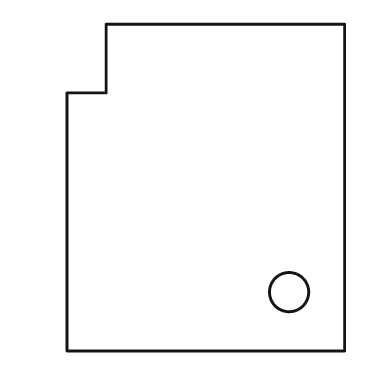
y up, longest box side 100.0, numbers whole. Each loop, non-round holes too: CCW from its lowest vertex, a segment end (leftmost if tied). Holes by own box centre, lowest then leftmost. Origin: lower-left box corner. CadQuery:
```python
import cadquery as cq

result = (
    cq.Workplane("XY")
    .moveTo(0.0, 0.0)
    .lineTo(85.0, 0.0)
    .lineTo(85.0, 100.0)
    .lineTo(12.0, 100.0)
    .lineTo(12.0, 79.0)
    .lineTo(0.0, 79.0)
    .close()
    .moveTo(68.0, 18.0)
    .circle(6.0)
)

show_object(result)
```